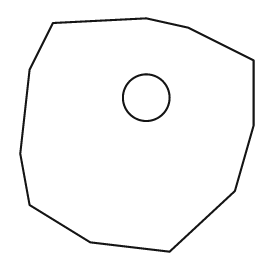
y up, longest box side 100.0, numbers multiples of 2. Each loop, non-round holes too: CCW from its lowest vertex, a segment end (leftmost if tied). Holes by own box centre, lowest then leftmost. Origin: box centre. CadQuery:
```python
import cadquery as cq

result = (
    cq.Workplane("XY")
    .moveTo(14.0, -50.0)
    .lineTo(42.0, -24.0)
    .lineTo(50.0, 4.0)
    .lineTo(50.0, 32.0)
    .lineTo(22.0, 46.0)
    .lineTo(4.0, 50.0)
    .lineTo(-36.0, 48.0)
    .lineTo(-46.0, 28.0)
    .lineTo(-50.0, -8.0)
    .lineTo(-46.0, -30.0)
    .lineTo(-20.0, -46.0)
    .close()
    .moveTo(4.0, 16.0)
    .circle(10.0)
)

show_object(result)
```